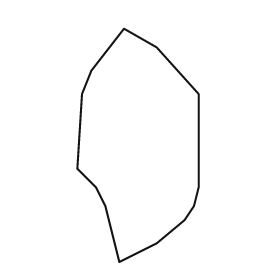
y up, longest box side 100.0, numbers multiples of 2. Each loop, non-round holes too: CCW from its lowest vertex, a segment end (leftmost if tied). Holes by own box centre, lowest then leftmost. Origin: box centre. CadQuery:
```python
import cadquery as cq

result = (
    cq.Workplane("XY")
    .moveTo(-8.0, -50.0)
    .lineTo(8.0, -42.0)
    .lineTo(20.0, -32.0)
    .lineTo(24.0, -26.0)
    .lineTo(26.0, -18.0)
    .lineTo(26.0, 22.0)
    .lineTo(8.0, 42.0)
    .lineTo(-6.0, 50.0)
    .lineTo(-20.0, 32.0)
    .lineTo(-24.0, 22.0)
    .lineTo(-26.0, -10.0)
    .lineTo(-18.0, -18.0)
    .lineTo(-14.0, -26.0)
    .close()
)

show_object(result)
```